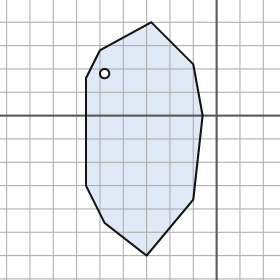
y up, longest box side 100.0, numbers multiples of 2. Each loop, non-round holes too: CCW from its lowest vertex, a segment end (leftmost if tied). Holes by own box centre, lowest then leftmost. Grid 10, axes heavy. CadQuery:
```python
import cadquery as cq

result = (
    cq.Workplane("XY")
    .moveTo(-30.0, -60.0)
    .lineTo(-10.0, -36.0)
    .lineTo(-6.0, 0.0)
    .lineTo(-10.0, 22.0)
    .lineTo(-28.0, 40.0)
    .lineTo(-50.0, 28.0)
    .lineTo(-56.0, 16.0)
    .lineTo(-56.0, -30.0)
    .lineTo(-48.0, -46.0)
    .close()
    .moveTo(-48.0, 18.0)
    .circle(2.0)
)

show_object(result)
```